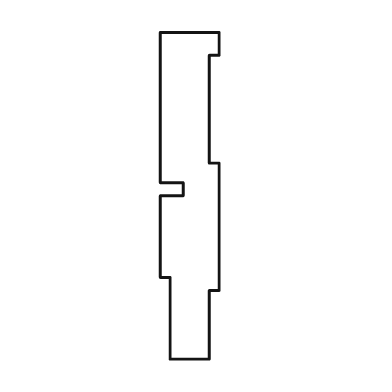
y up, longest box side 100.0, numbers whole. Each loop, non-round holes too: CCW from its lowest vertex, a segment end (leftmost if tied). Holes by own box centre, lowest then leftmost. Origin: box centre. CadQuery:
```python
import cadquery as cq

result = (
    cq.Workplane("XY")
    .moveTo(-6.0, -50.0)
    .lineTo(6.0, -50.0)
    .lineTo(6.0, -29.0)
    .lineTo(9.0, -29.0)
    .lineTo(9.0, 10.0)
    .lineTo(6.0, 10.0)
    .lineTo(6.0, 43.0)
    .lineTo(9.0, 43.0)
    .lineTo(9.0, 50.0)
    .lineTo(-9.0, 50.0)
    .lineTo(-9.0, 4.0)
    .lineTo(-2.0, 4.0)
    .lineTo(-2.0, 0.0)
    .lineTo(-9.0, 0.0)
    .lineTo(-9.0, -25.0)
    .lineTo(-6.0, -25.0)
    .close()
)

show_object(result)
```